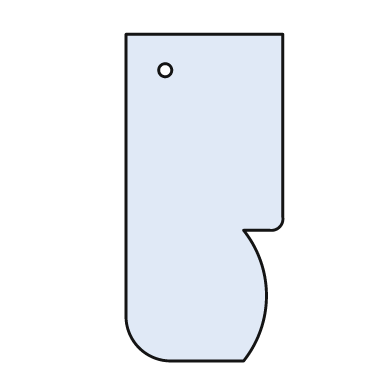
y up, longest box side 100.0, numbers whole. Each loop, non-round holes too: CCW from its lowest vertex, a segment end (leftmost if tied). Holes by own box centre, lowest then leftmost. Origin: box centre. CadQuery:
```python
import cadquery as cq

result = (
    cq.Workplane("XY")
    .moveTo(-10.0, -50.0)
    .lineTo(12.0, -50.0)
    .threePointArc((19.0, -30.0), (12.0, -10.0))
    .lineTo(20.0, -10.0)
    .threePointArc((23.0, -9.0), (24.0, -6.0))
    .lineTo(24.0, 50.0)
    .lineTo(-24.0, 50.0)
    .lineTo(-24.0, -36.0)
    .threePointArc((-20.0, -46.0), (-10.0, -50.0))
    .close()
    .moveTo(-12.0, 39.0)
    .circle(2.0)
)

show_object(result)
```